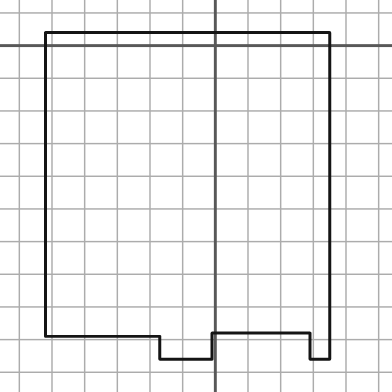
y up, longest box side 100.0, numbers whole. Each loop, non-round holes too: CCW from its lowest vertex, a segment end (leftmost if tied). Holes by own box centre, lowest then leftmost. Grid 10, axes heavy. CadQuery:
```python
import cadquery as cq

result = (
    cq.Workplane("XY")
    .moveTo(-17.0, -96.0)
    .lineTo(-1.0, -96.0)
    .lineTo(-1.0, -88.0)
    .lineTo(29.0, -88.0)
    .lineTo(29.0, -96.0)
    .lineTo(35.0, -96.0)
    .lineTo(35.0, 4.0)
    .lineTo(-52.0, 4.0)
    .lineTo(-52.0, -89.0)
    .lineTo(-17.0, -89.0)
    .close()
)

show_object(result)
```